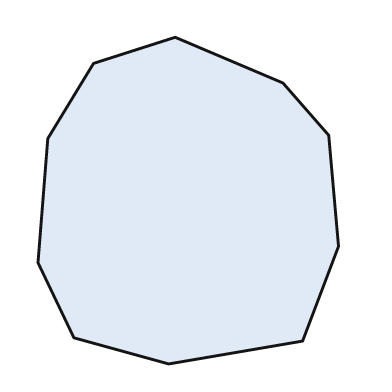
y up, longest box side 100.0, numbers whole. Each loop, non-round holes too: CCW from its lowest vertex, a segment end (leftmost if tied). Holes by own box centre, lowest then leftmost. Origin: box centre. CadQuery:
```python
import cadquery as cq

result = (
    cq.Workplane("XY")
    .moveTo(-6.0, -50.0)
    .lineTo(35.0, -43.0)
    .lineTo(46.0, -14.0)
    .lineTo(43.0, 20.0)
    .lineTo(29.0, 36.0)
    .lineTo(-4.0, 50.0)
    .lineTo(-29.0, 42.0)
    .lineTo(-43.0, 19.0)
    .lineTo(-46.0, -19.0)
    .lineTo(-35.0, -42.0)
    .close()
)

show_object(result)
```